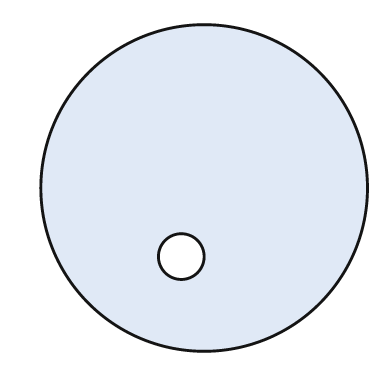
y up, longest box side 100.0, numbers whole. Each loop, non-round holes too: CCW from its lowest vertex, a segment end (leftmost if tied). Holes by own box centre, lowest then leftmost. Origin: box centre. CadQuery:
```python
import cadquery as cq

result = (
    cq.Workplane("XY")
    .moveTo(0.0, 0.0)
    .circle(50.0)
    .moveTo(-7.0, -21.0)
    .circle(7.0)
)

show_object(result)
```